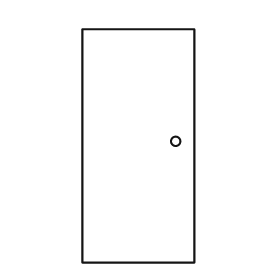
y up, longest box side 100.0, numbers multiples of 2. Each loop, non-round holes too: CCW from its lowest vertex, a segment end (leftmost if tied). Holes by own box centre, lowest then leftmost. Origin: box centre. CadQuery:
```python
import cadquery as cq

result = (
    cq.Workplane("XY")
    .moveTo(-24.0, -50.0)
    .lineTo(24.0, -50.0)
    .lineTo(24.0, 50.0)
    .lineTo(-24.0, 50.0)
    .close()
    .moveTo(16.0, 2.0)
    .circle(2.0)
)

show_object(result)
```